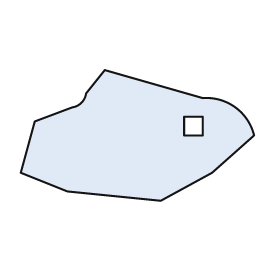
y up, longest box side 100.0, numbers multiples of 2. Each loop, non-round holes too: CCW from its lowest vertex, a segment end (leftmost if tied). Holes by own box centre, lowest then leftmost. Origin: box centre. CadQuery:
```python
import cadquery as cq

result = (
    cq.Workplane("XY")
    .moveTo(10.0, -28.0)
    .lineTo(32.0, -16.0)
    .lineTo(50.0, 0.0)
    .threePointArc((42.0, 12.0), (28.0, 16.0))
    .lineTo(-14.0, 28.0)
    .lineTo(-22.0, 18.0)
    .threePointArc((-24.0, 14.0), (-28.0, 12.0))
    .lineTo(-44.0, 6.0)
    .lineTo(-50.0, -16.0)
    .lineTo(-30.0, -24.0)
    .close()
    .moveTo(20.0, 0.0)
    .lineTo(28.0, 0.0)
    .lineTo(28.0, 8.0)
    .lineTo(20.0, 8.0)
    .close()
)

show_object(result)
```